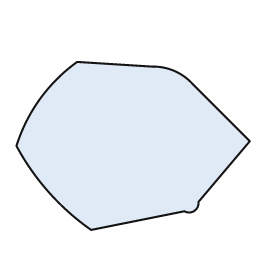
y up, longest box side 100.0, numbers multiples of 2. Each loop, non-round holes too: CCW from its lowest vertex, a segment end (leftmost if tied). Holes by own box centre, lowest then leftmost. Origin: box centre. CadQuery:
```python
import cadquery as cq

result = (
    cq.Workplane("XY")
    .moveTo(-18.0, -36.0)
    .lineTo(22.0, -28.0)
    .threePointArc((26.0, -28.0), (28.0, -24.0))
    .lineTo(50.0, 2.0)
    .lineTo(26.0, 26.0)
    .threePointArc((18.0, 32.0), (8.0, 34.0))
    .lineTo(-24.0, 36.0)
    .threePointArc((-40.0, 20.0), (-50.0, 0.0))
    .threePointArc((-36.0, -20.0), (-18.0, -36.0))
    .close()
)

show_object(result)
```